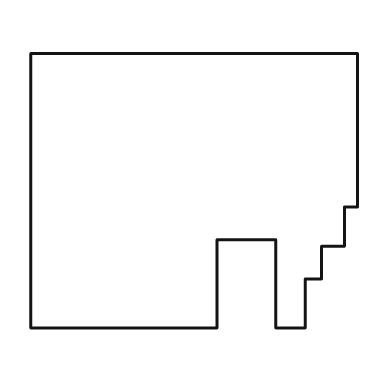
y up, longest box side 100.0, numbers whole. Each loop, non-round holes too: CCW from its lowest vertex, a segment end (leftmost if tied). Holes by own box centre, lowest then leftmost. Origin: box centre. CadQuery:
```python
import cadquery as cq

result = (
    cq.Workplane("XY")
    .moveTo(-50.0, -42.0)
    .lineTo(7.0, -42.0)
    .lineTo(7.0, -15.0)
    .lineTo(25.0, -15.0)
    .lineTo(25.0, -42.0)
    .lineTo(34.0, -42.0)
    .lineTo(34.0, -27.0)
    .lineTo(39.0, -27.0)
    .lineTo(39.0, -17.0)
    .lineTo(46.0, -17.0)
    .lineTo(46.0, -5.0)
    .lineTo(50.0, -5.0)
    .lineTo(50.0, 42.0)
    .lineTo(-50.0, 42.0)
    .close()
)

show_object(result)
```